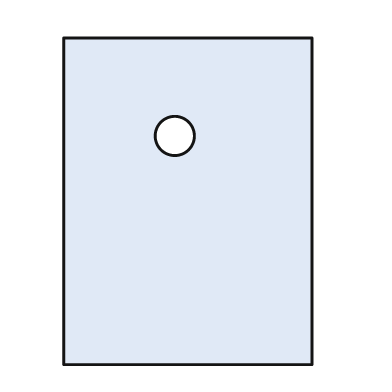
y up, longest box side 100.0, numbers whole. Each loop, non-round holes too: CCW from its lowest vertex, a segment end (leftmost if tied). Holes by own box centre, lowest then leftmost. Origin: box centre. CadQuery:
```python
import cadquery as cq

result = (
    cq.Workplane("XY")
    .moveTo(-38.0, -50.0)
    .lineTo(38.0, -50.0)
    .lineTo(38.0, 50.0)
    .lineTo(-38.0, 50.0)
    .close()
    .moveTo(-4.0, 20.0)
    .circle(6.0)
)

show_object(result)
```